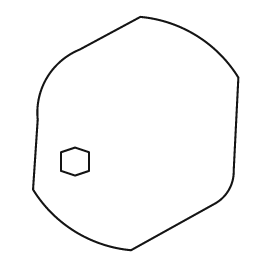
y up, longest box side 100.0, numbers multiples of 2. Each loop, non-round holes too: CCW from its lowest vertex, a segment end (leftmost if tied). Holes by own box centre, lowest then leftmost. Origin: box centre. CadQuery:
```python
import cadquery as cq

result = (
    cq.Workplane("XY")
    .moveTo(-2.0, -50.0)
    .lineTo(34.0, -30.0)
    .threePointArc((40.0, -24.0), (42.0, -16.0))
    .lineTo(44.0, 24.0)
    .threePointArc((26.0, 42.0), (2.0, 50.0))
    .lineTo(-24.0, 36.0)
    .threePointArc((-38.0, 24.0), (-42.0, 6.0))
    .lineTo(-44.0, -24.0)
    .threePointArc((-26.0, -42.0), (-2.0, -50.0))
    .close()
    .moveTo(-26.0, -18.0)
    .lineTo(-20.0, -16.0)
    .lineTo(-20.0, -8.0)
    .lineTo(-26.0, -6.0)
    .lineTo(-32.0, -8.0)
    .lineTo(-32.0, -16.0)
    .close()
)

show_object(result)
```